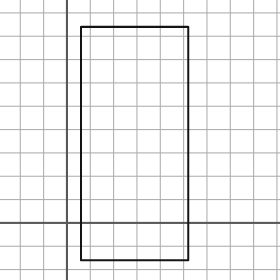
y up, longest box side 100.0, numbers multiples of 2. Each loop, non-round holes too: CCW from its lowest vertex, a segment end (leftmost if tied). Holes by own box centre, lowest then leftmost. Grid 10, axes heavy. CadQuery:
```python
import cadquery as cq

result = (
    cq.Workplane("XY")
    .moveTo(6.0, -16.0)
    .lineTo(52.0, -16.0)
    .lineTo(52.0, 84.0)
    .lineTo(6.0, 84.0)
    .close()
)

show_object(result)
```